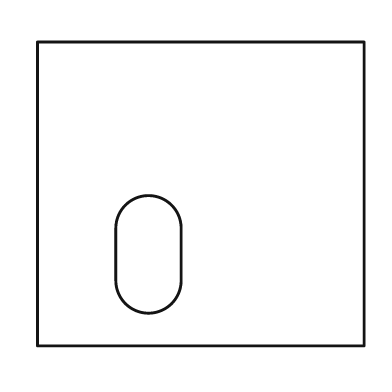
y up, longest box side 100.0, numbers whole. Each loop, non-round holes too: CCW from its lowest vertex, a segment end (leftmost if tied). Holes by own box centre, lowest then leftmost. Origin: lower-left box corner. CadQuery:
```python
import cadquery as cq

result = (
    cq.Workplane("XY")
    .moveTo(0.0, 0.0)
    .lineTo(100.0, 0.0)
    .lineTo(100.0, 93.0)
    .lineTo(0.0, 93.0)
    .close()
    .moveTo(24.0, 20.0)
    .threePointArc((34.0, 10.0), (44.0, 20.0))
    .lineTo(44.0, 36.0)
    .threePointArc((34.0, 46.0), (24.0, 36.0))
    .close()
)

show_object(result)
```